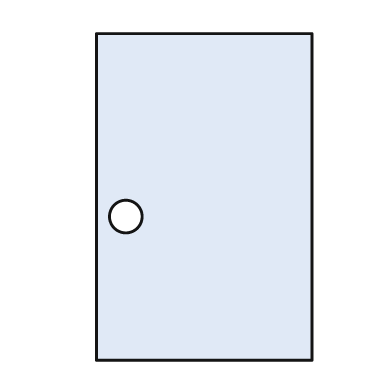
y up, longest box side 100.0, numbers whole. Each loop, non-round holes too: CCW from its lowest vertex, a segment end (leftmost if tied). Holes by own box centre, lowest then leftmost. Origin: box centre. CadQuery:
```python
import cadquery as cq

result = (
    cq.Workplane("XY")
    .moveTo(-33.0, -50.0)
    .lineTo(33.0, -50.0)
    .lineTo(33.0, 50.0)
    .lineTo(-33.0, 50.0)
    .close()
    .moveTo(-24.0, -6.0)
    .circle(5.0)
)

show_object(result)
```